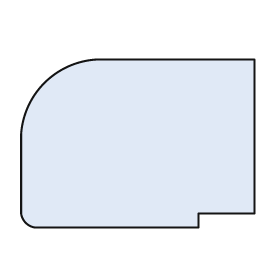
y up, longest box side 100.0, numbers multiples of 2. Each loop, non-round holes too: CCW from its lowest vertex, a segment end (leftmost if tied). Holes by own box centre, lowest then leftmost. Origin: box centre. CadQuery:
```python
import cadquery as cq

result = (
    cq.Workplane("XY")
    .moveTo(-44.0, -36.0)
    .lineTo(26.0, -36.0)
    .lineTo(26.0, -30.0)
    .lineTo(50.0, -30.0)
    .lineTo(50.0, 36.0)
    .lineTo(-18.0, 36.0)
    .threePointArc((-40.0, 26.0), (-50.0, 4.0))
    .lineTo(-50.0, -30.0)
    .threePointArc((-48.0, -34.0), (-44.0, -36.0))
    .close()
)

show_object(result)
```